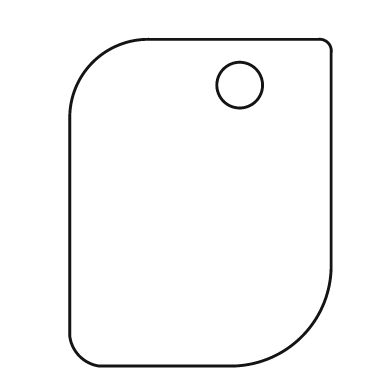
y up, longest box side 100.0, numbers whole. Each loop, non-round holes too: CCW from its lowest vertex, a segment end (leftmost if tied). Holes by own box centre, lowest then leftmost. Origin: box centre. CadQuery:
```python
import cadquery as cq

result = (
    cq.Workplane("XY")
    .moveTo(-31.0, -50.0)
    .lineTo(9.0, -50.0)
    .threePointArc((31.0, -41.0), (40.0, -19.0))
    .lineTo(40.0, 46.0)
    .threePointArc((39.0, 49.0), (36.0, 50.0))
    .lineTo(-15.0, 50.0)
    .threePointArc((-33.0, 43.0), (-40.0, 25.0))
    .lineTo(-40.0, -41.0)
    .threePointArc((-37.0, -47.0), (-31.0, -50.0))
    .close()
    .moveTo(12.0, 36.0)
    .circle(7.0)
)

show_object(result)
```